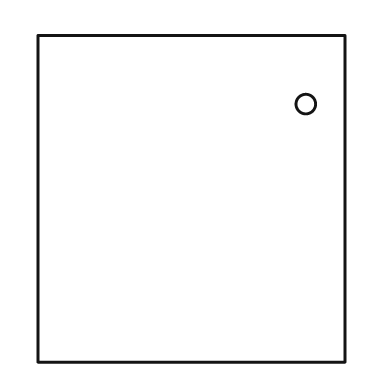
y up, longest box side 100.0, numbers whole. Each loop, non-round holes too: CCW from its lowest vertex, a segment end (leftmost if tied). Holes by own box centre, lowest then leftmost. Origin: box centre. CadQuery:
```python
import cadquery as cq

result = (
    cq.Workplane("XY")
    .moveTo(-47.0, -50.0)
    .lineTo(47.0, -50.0)
    .lineTo(47.0, 50.0)
    .lineTo(-47.0, 50.0)
    .close()
    .moveTo(35.0, 29.0)
    .circle(3.0)
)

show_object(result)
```